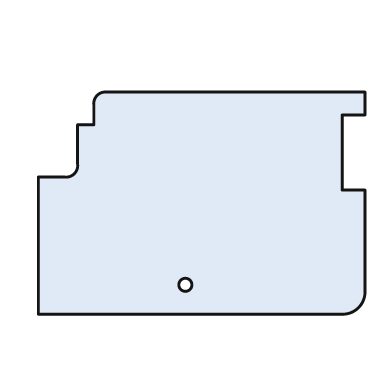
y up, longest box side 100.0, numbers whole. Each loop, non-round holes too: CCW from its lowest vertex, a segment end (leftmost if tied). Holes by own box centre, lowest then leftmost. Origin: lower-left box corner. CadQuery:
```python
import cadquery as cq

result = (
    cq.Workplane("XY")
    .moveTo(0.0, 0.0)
    .lineTo(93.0, 0.0)
    .threePointArc((98.0, 2.0), (100.0, 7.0))
    .lineTo(100.0, 38.0)
    .lineTo(93.0, 38.0)
    .lineTo(93.0, 61.0)
    .lineTo(100.0, 61.0)
    .lineTo(100.0, 68.0)
    .lineTo(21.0, 68.0)
    .threePointArc((18.0, 67.0), (17.0, 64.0))
    .lineTo(17.0, 58.0)
    .lineTo(12.0, 58.0)
    .lineTo(12.0, 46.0)
    .threePointArc((11.0, 43.0), (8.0, 42.0))
    .lineTo(0.0, 42.0)
    .close()
    .moveTo(45.0, 9.0)
    .circle(2.0)
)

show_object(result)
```